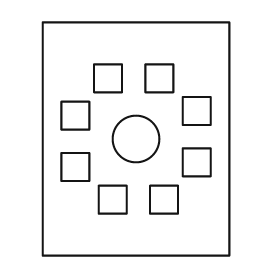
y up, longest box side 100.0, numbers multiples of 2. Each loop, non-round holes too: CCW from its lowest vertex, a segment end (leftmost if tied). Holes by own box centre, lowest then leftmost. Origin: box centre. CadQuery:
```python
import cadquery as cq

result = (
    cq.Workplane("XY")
    .moveTo(-40.0, -50.0)
    .lineTo(40.0, -50.0)
    .lineTo(40.0, 50.0)
    .lineTo(-40.0, 50.0)
    .close()
    .moveTo(-16.0, -32.0)
    .lineTo(-4.0, -32.0)
    .lineTo(-4.0, -20.0)
    .lineTo(-16.0, -20.0)
    .close()
    .moveTo(6.0, -32.0)
    .lineTo(18.0, -32.0)
    .lineTo(18.0, -20.0)
    .lineTo(6.0, -20.0)
    .close()
    .moveTo(-32.0, -18.0)
    .lineTo(-20.0, -18.0)
    .lineTo(-20.0, -6.0)
    .lineTo(-32.0, -6.0)
    .close()
    .moveTo(20.0, -16.0)
    .lineTo(32.0, -16.0)
    .lineTo(32.0, -4.0)
    .lineTo(20.0, -4.0)
    .close()
    .moveTo(0.0, 0.0)
    .circle(10.0)
    .moveTo(-32.0, 4.0)
    .lineTo(-20.0, 4.0)
    .lineTo(-20.0, 16.0)
    .lineTo(-32.0, 16.0)
    .close()
    .moveTo(20.0, 6.0)
    .lineTo(32.0, 6.0)
    .lineTo(32.0, 18.0)
    .lineTo(20.0, 18.0)
    .close()
    .moveTo(-18.0, 20.0)
    .lineTo(-6.0, 20.0)
    .lineTo(-6.0, 32.0)
    .lineTo(-18.0, 32.0)
    .close()
    .moveTo(4.0, 20.0)
    .lineTo(16.0, 20.0)
    .lineTo(16.0, 32.0)
    .lineTo(4.0, 32.0)
    .close()
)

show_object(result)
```